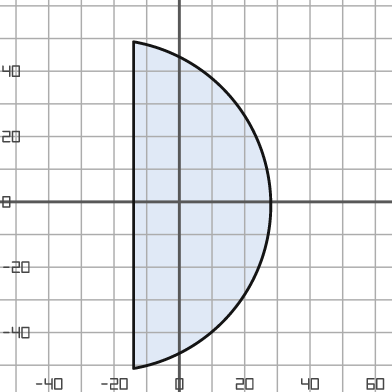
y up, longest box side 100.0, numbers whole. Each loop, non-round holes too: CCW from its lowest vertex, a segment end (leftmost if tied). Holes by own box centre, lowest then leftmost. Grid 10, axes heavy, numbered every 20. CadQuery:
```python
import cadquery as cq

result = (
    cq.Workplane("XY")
    .moveTo(-14.0, -51.0)
    .threePointArc((28.0, -1.0), (-14.0, 49.0))
    .close()
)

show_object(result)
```